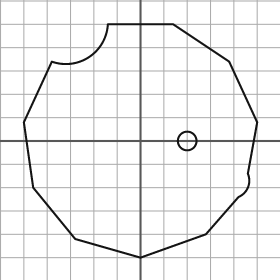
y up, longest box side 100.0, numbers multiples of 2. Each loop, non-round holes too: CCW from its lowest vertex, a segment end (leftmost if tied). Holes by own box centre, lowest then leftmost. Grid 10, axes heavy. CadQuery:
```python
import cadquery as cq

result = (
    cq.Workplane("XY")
    .moveTo(0.0, -50.0)
    .lineTo(28.0, -40.0)
    .lineTo(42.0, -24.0)
    .threePointArc((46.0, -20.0), (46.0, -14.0))
    .lineTo(50.0, 8.0)
    .lineTo(38.0, 34.0)
    .lineTo(14.0, 50.0)
    .lineTo(-14.0, 50.0)
    .threePointArc((-22.0, 36.0), (-38.0, 34.0))
    .lineTo(-50.0, 8.0)
    .lineTo(-46.0, -20.0)
    .lineTo(-28.0, -42.0)
    .close()
    .moveTo(20.0, 0.0)
    .circle(4.0)
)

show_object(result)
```